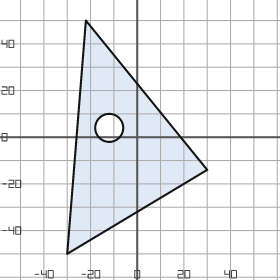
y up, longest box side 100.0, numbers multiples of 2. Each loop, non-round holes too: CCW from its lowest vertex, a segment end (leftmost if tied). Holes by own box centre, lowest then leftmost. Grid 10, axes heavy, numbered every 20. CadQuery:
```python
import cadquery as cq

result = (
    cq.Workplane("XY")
    .moveTo(-30.0, -50.0)
    .lineTo(30.0, -14.0)
    .lineTo(-22.0, 50.0)
    .close()
    .moveTo(-12.0, 4.0)
    .circle(6.0)
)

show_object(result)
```